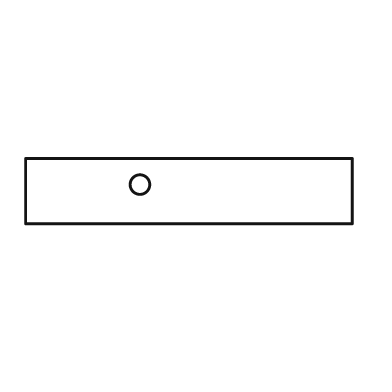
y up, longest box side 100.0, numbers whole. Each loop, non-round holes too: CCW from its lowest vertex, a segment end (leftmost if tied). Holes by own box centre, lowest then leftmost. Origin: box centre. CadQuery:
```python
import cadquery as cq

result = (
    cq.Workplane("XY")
    .moveTo(-50.0, -10.0)
    .lineTo(50.0, -10.0)
    .lineTo(50.0, 10.0)
    .lineTo(-50.0, 10.0)
    .close()
    .moveTo(-15.0, 2.0)
    .circle(3.0)
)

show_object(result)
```